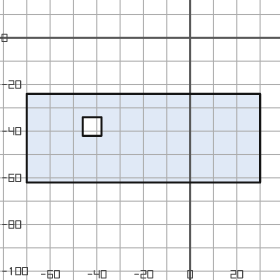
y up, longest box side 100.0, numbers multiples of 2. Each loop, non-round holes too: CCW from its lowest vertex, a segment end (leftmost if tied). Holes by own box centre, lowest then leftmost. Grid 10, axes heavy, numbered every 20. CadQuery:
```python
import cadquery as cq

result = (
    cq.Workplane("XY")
    .moveTo(-70.0, -62.0)
    .lineTo(30.0, -62.0)
    .lineTo(30.0, -24.0)
    .lineTo(-70.0, -24.0)
    .close()
    .moveTo(-46.0, -42.0)
    .lineTo(-38.0, -42.0)
    .lineTo(-38.0, -34.0)
    .lineTo(-46.0, -34.0)
    .close()
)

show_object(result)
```